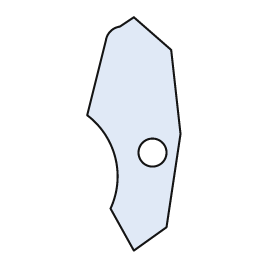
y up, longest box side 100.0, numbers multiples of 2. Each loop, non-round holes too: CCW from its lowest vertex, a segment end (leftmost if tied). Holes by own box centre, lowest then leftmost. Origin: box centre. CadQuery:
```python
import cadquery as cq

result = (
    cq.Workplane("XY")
    .moveTo(0.0, -50.0)
    .lineTo(14.0, -40.0)
    .lineTo(20.0, 0.0)
    .lineTo(16.0, 36.0)
    .lineTo(0.0, 50.0)
    .lineTo(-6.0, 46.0)
    .threePointArc((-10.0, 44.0), (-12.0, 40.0))
    .lineTo(-20.0, 8.0)
    .threePointArc((-8.0, -10.0), (-10.0, -32.0))
    .close()
    .moveTo(8.0, -8.0)
    .circle(6.0)
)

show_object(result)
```